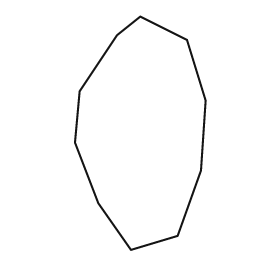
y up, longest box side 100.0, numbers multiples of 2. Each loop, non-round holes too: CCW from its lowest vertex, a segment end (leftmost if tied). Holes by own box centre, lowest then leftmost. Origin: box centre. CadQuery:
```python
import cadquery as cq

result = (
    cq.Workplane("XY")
    .moveTo(-4.0, -50.0)
    .lineTo(16.0, -44.0)
    .lineTo(26.0, -16.0)
    .lineTo(28.0, 14.0)
    .lineTo(20.0, 40.0)
    .lineTo(0.0, 50.0)
    .lineTo(-10.0, 42.0)
    .lineTo(-26.0, 18.0)
    .lineTo(-28.0, -4.0)
    .lineTo(-18.0, -30.0)
    .close()
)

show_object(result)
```